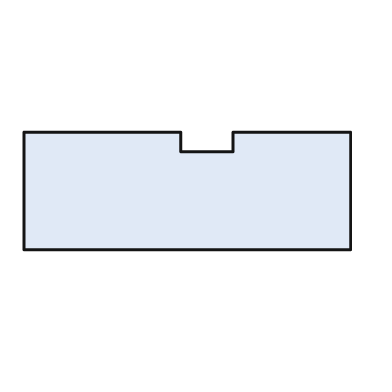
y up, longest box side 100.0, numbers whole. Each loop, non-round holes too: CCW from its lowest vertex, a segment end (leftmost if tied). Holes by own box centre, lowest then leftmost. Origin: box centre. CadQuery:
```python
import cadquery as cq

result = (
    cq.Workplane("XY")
    .moveTo(-50.0, -18.0)
    .lineTo(50.0, -18.0)
    .lineTo(50.0, 18.0)
    .lineTo(14.0, 18.0)
    .lineTo(14.0, 12.0)
    .lineTo(-2.0, 12.0)
    .lineTo(-2.0, 18.0)
    .lineTo(-50.0, 18.0)
    .close()
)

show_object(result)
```